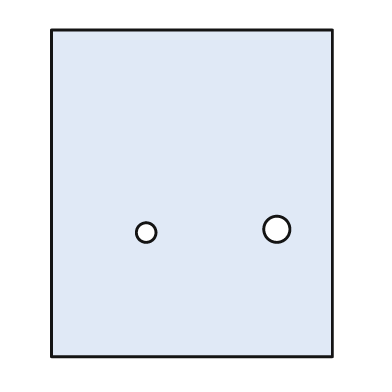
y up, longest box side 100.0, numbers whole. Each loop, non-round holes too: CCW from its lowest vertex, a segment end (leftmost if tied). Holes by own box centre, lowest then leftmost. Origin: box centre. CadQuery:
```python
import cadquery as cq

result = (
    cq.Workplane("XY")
    .moveTo(-43.0, -50.0)
    .lineTo(43.0, -50.0)
    .lineTo(43.0, 50.0)
    .lineTo(-43.0, 50.0)
    .close()
    .moveTo(-14.0, -12.0)
    .circle(3.0)
    .moveTo(26.0, -11.0)
    .circle(4.0)
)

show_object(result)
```